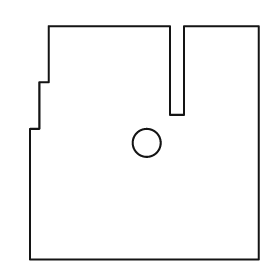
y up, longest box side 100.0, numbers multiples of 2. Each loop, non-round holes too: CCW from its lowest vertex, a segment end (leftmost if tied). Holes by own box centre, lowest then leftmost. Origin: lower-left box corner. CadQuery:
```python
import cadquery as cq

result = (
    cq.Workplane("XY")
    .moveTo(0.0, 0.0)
    .lineTo(98.0, 0.0)
    .lineTo(98.0, 100.0)
    .lineTo(66.0, 100.0)
    .lineTo(66.0, 62.0)
    .lineTo(60.0, 62.0)
    .lineTo(60.0, 100.0)
    .lineTo(8.0, 100.0)
    .lineTo(8.0, 76.0)
    .lineTo(4.0, 76.0)
    .lineTo(4.0, 56.0)
    .lineTo(0.0, 56.0)
    .close()
    .moveTo(50.0, 50.0)
    .circle(6.0)
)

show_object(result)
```